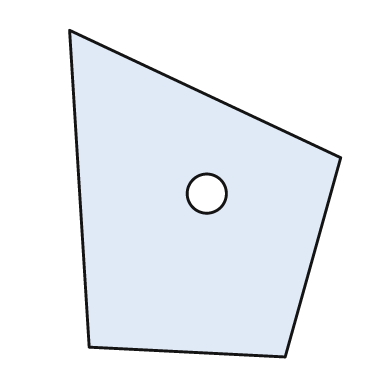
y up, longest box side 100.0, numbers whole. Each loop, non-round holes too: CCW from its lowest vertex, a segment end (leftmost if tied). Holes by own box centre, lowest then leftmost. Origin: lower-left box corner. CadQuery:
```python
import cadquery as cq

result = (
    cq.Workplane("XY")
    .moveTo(66.0, 0.0)
    .lineTo(83.0, 61.0)
    .lineTo(0.0, 100.0)
    .lineTo(6.0, 3.0)
    .close()
    .moveTo(42.0, 50.0)
    .circle(6.0)
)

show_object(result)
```